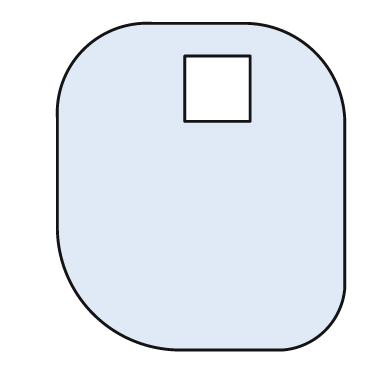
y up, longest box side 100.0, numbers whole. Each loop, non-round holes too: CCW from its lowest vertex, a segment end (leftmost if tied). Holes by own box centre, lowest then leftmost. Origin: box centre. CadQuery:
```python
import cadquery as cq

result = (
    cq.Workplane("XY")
    .moveTo(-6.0, -50.0)
    .lineTo(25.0, -50.0)
    .threePointArc((38.0, -44.0), (44.0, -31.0))
    .lineTo(44.0, 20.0)
    .threePointArc((35.0, 41.0), (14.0, 50.0))
    .lineTo(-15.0, 50.0)
    .threePointArc((-36.0, 42.0), (-44.0, 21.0))
    .lineTo(-44.0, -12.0)
    .threePointArc((-33.0, -39.0), (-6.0, -50.0))
    .close()
    .moveTo(-5.0, 20.0)
    .lineTo(15.0, 20.0)
    .lineTo(15.0, 40.0)
    .lineTo(-5.0, 40.0)
    .close()
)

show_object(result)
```